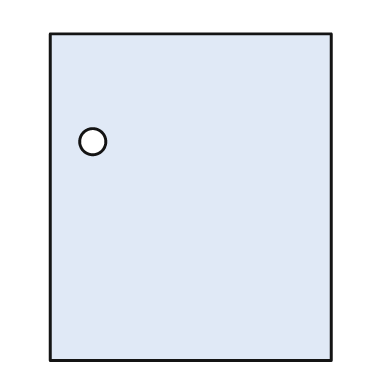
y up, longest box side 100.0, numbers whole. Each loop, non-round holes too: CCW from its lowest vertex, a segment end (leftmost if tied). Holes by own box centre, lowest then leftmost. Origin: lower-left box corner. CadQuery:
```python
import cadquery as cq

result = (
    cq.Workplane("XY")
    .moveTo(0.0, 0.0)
    .lineTo(86.0, 0.0)
    .lineTo(86.0, 100.0)
    .lineTo(0.0, 100.0)
    .close()
    .moveTo(13.0, 67.0)
    .circle(4.0)
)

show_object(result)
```